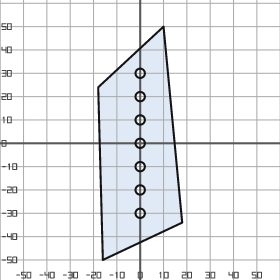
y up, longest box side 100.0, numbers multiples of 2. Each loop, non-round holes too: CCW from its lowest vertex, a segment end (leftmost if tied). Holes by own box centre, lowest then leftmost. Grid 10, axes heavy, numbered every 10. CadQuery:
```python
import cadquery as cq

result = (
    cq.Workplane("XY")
    .moveTo(-16.0, -50.0)
    .lineTo(18.0, -34.0)
    .lineTo(10.0, 50.0)
    .lineTo(-18.0, 24.0)
    .close()
    .moveTo(0.0, -30.0)
    .circle(2.0)
    .moveTo(0.0, -20.0)
    .circle(2.0)
    .moveTo(0.0, -10.0)
    .circle(2.0)
    .moveTo(0.0, 0.0)
    .circle(2.0)
    .moveTo(0.0, 10.0)
    .circle(2.0)
    .moveTo(0.0, 20.0)
    .circle(2.0)
    .moveTo(0.0, 30.0)
    .circle(2.0)
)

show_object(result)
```